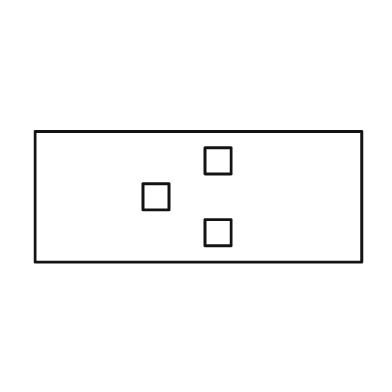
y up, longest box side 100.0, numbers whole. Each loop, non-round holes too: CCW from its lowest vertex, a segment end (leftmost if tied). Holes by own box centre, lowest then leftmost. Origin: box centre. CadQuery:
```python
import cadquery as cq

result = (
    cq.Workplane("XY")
    .moveTo(-50.0, -20.0)
    .lineTo(50.0, -20.0)
    .lineTo(50.0, 20.0)
    .lineTo(-50.0, 20.0)
    .close()
    .moveTo(2.0, -15.0)
    .lineTo(10.0, -15.0)
    .lineTo(10.0, -7.0)
    .lineTo(2.0, -7.0)
    .close()
    .moveTo(-17.0, -4.0)
    .lineTo(-9.0, -4.0)
    .lineTo(-9.0, 4.0)
    .lineTo(-17.0, 4.0)
    .close()
    .moveTo(2.0, 7.0)
    .lineTo(10.0, 7.0)
    .lineTo(10.0, 15.0)
    .lineTo(2.0, 15.0)
    .close()
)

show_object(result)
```